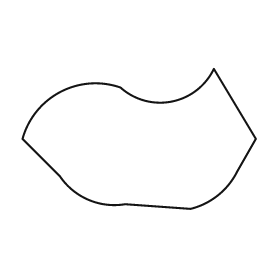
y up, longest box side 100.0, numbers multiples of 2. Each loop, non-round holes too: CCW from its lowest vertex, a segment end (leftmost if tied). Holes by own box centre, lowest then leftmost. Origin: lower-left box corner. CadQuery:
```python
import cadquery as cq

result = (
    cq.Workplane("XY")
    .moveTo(72.0, 0.0)
    .threePointArc((84.0, 6.0), (92.0, 16.0))
    .lineTo(100.0, 30.0)
    .lineTo(82.0, 60.0)
    .threePointArc((64.0, 46.0), (42.0, 52.0))
    .threePointArc((16.0, 50.0), (0.0, 30.0))
    .lineTo(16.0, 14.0)
    .threePointArc((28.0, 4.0), (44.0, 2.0))
    .close()
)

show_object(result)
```